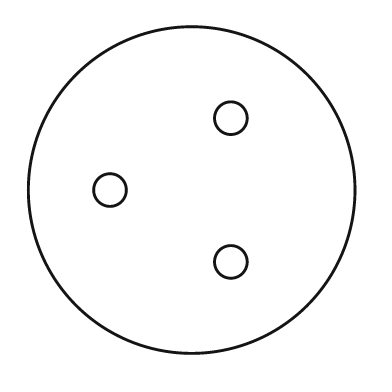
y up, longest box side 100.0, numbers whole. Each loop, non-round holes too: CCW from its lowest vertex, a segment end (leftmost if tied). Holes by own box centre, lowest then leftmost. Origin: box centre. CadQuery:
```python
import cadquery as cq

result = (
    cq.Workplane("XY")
    .moveTo(0.0, 0.0)
    .circle(50.0)
    .moveTo(12.0, -22.0)
    .circle(5.0)
    .moveTo(-25.0, 0.0)
    .circle(5.0)
    .moveTo(12.0, 22.0)
    .circle(5.0)
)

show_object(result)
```